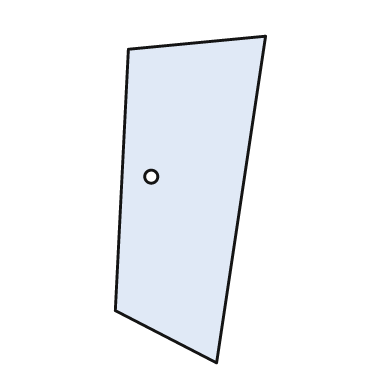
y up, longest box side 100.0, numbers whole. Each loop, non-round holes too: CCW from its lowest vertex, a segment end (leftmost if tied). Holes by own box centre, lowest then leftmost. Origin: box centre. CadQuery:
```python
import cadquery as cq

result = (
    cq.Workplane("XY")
    .moveTo(8.0, -50.0)
    .lineTo(23.0, 50.0)
    .lineTo(-19.0, 46.0)
    .lineTo(-23.0, -34.0)
    .close()
    .moveTo(-12.0, 7.0)
    .circle(2.0)
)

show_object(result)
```